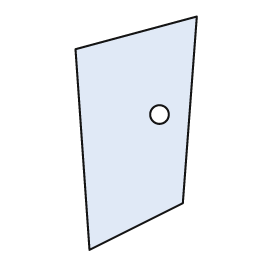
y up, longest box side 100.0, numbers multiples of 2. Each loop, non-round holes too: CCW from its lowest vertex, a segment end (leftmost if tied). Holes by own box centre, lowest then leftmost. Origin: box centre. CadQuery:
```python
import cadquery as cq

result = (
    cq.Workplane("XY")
    .moveTo(-20.0, -50.0)
    .lineTo(20.0, -30.0)
    .lineTo(26.0, 50.0)
    .lineTo(-26.0, 36.0)
    .close()
    .moveTo(10.0, 8.0)
    .circle(4.0)
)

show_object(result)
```